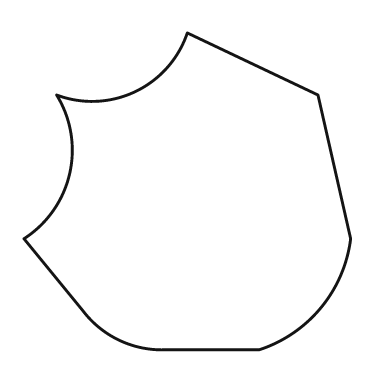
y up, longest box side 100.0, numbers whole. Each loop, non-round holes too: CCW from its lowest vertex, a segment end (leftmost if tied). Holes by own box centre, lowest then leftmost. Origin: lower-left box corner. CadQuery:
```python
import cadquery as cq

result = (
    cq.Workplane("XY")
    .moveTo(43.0, 0.0)
    .lineTo(72.0, 0.0)
    .threePointArc((91.0, 13.0), (100.0, 34.0))
    .lineTo(90.0, 78.0)
    .lineTo(50.0, 97.0)
    .threePointArc((34.0, 79.0), (10.0, 78.0))
    .threePointArc((14.0, 54.0), (0.0, 34.0))
    .lineTo(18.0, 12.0)
    .threePointArc((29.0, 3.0), (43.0, 0.0))
    .close()
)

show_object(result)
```